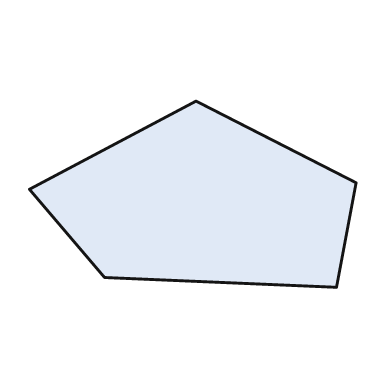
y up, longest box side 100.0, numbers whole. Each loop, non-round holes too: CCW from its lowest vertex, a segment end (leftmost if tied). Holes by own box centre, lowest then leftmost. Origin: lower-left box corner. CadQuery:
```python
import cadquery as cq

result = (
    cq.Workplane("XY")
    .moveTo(94.0, 0.0)
    .lineTo(100.0, 32.0)
    .lineTo(51.0, 57.0)
    .lineTo(0.0, 30.0)
    .lineTo(23.0, 3.0)
    .close()
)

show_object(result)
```